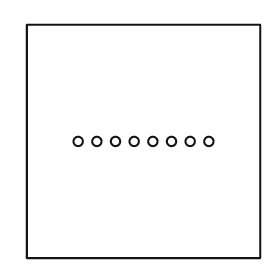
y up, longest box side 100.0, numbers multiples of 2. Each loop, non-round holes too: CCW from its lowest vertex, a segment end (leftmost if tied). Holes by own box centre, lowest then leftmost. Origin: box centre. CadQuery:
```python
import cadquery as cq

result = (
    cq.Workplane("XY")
    .moveTo(-50.0, -50.0)
    .lineTo(50.0, -50.0)
    .lineTo(50.0, 50.0)
    .lineTo(-50.0, 50.0)
    .close()
    .moveTo(-28.0, 0.0)
    .circle(2.0)
    .moveTo(-20.0, 0.0)
    .circle(2.0)
    .moveTo(-12.0, 0.0)
    .circle(2.0)
    .moveTo(-4.0, 0.0)
    .circle(2.0)
    .moveTo(4.0, 0.0)
    .circle(2.0)
    .moveTo(12.0, 0.0)
    .circle(2.0)
    .moveTo(20.0, 0.0)
    .circle(2.0)
    .moveTo(28.0, 0.0)
    .circle(2.0)
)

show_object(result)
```